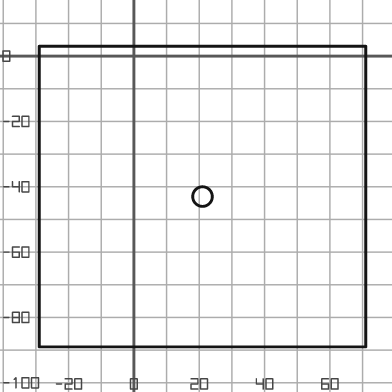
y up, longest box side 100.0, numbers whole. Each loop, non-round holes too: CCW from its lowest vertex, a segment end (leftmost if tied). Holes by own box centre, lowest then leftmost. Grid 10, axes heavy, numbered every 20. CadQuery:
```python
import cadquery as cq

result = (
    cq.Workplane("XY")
    .moveTo(-29.0, -89.0)
    .lineTo(71.0, -89.0)
    .lineTo(71.0, 3.0)
    .lineTo(-29.0, 3.0)
    .close()
    .moveTo(21.0, -43.0)
    .circle(3.0)
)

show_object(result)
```